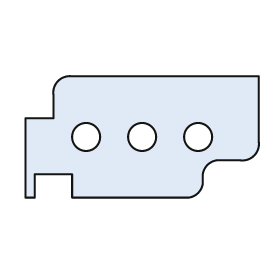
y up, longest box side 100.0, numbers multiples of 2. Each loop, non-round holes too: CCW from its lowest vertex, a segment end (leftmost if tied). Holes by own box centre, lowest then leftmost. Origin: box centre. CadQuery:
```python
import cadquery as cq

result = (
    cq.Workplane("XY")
    .moveTo(-50.0, -26.0)
    .lineTo(-46.0, -26.0)
    .lineTo(-46.0, -16.0)
    .lineTo(-30.0, -16.0)
    .lineTo(-30.0, -26.0)
    .lineTo(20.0, -26.0)
    .threePointArc((24.0, -24.0), (26.0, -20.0))
    .lineTo(26.0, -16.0)
    .threePointArc((28.0, -12.0), (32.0, -10.0))
    .lineTo(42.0, -10.0)
    .threePointArc((48.0, -8.0), (50.0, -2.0))
    .lineTo(50.0, 26.0)
    .lineTo(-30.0, 26.0)
    .threePointArc((-36.0, 24.0), (-38.0, 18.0))
    .lineTo(-38.0, 8.0)
    .lineTo(-50.0, 8.0)
    .close()
    .moveTo(-24.0, 0.0)
    .circle(6.0)
    .moveTo(0.0, 0.0)
    .circle(6.0)
    .moveTo(24.0, 0.0)
    .circle(6.0)
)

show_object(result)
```